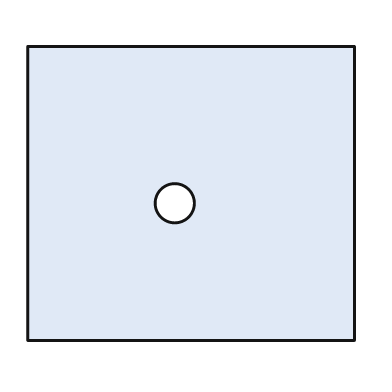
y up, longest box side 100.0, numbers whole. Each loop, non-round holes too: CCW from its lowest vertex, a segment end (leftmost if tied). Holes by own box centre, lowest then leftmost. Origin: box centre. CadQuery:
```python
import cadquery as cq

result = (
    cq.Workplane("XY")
    .moveTo(-50.0, -45.0)
    .lineTo(50.0, -45.0)
    .lineTo(50.0, 45.0)
    .lineTo(-50.0, 45.0)
    .close()
    .moveTo(-5.0, -3.0)
    .circle(6.0)
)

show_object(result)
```